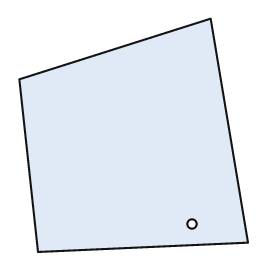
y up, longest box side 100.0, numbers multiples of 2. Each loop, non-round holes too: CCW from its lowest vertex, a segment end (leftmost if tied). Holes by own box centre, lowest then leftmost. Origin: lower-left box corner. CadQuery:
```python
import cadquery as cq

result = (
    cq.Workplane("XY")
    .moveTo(8.0, 0.0)
    .lineTo(98.0, 4.0)
    .lineTo(82.0, 100.0)
    .lineTo(0.0, 74.0)
    .close()
    .moveTo(74.0, 12.0)
    .circle(2.0)
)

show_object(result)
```